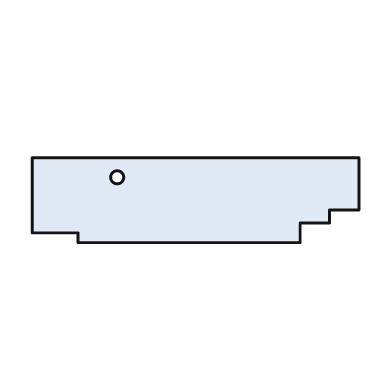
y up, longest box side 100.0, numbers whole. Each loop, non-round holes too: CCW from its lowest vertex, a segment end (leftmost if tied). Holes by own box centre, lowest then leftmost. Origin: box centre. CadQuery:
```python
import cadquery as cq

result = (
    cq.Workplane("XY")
    .moveTo(-36.0, -13.0)
    .lineTo(32.0, -13.0)
    .lineTo(32.0, -7.0)
    .lineTo(41.0, -7.0)
    .lineTo(41.0, -3.0)
    .lineTo(50.0, -3.0)
    .lineTo(50.0, 13.0)
    .lineTo(-50.0, 13.0)
    .lineTo(-50.0, -10.0)
    .lineTo(-36.0, -10.0)
    .close()
    .moveTo(-24.0, 7.0)
    .circle(2.0)
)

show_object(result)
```